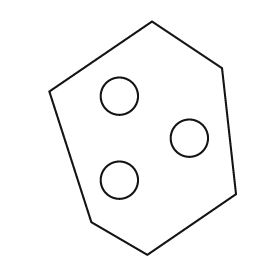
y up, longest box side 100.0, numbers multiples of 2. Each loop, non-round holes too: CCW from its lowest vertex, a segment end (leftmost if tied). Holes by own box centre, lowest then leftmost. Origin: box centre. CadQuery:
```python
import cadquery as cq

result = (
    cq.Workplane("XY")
    .moveTo(2.0, -50.0)
    .lineTo(40.0, -24.0)
    .lineTo(34.0, 30.0)
    .lineTo(4.0, 50.0)
    .lineTo(-40.0, 20.0)
    .lineTo(-22.0, -36.0)
    .close()
    .moveTo(-10.0, -18.0)
    .circle(8.0)
    .moveTo(20.0, 0.0)
    .circle(8.0)
    .moveTo(-10.0, 18.0)
    .circle(8.0)
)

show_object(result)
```